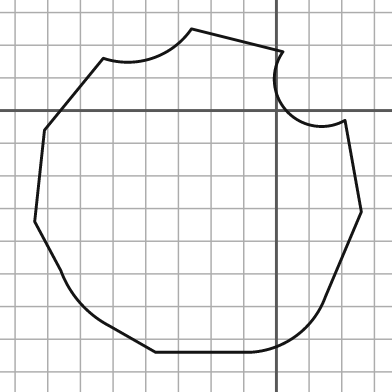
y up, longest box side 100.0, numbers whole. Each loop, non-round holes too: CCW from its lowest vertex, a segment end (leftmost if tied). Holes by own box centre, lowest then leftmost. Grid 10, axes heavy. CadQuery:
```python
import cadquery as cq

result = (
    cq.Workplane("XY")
    .moveTo(-37.0, -74.0)
    .lineTo(-8.0, -74.0)
    .threePointArc((6.0, -69.0), (15.0, -57.0))
    .lineTo(26.0, -31.0)
    .lineTo(21.0, -3.0)
    .threePointArc((3.0, 0.0), (2.0, 18.0))
    .lineTo(-26.0, 25.0)
    .threePointArc((-38.0, 16.0), (-53.0, 16.0))
    .lineTo(-71.0, -6.0)
    .lineTo(-74.0, -34.0)
    .lineTo(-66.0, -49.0)
    .threePointArc((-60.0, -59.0), (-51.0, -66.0))
    .close()
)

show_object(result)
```